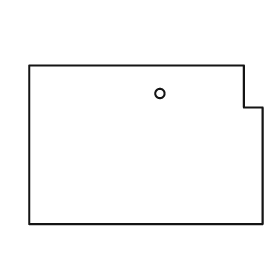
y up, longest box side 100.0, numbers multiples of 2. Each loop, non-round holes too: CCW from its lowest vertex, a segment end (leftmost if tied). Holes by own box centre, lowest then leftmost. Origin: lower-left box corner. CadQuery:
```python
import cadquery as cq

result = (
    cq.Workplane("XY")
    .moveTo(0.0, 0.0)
    .lineTo(100.0, 0.0)
    .lineTo(100.0, 50.0)
    .lineTo(92.0, 50.0)
    .lineTo(92.0, 68.0)
    .lineTo(0.0, 68.0)
    .close()
    .moveTo(56.0, 56.0)
    .circle(2.0)
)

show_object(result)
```